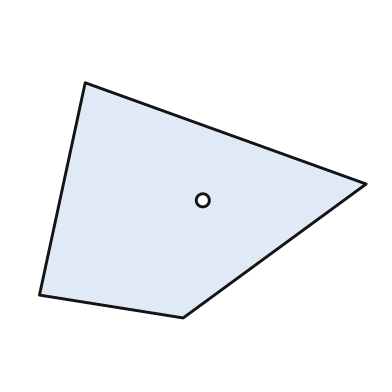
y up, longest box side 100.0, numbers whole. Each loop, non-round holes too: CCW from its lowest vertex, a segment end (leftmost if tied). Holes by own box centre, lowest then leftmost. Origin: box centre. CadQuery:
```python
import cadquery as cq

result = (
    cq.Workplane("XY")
    .moveTo(-6.0, -36.0)
    .lineTo(50.0, 5.0)
    .lineTo(-36.0, 36.0)
    .lineTo(-50.0, -29.0)
    .close()
    .moveTo(0.0, 0.0)
    .circle(2.0)
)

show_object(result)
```